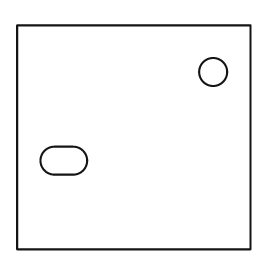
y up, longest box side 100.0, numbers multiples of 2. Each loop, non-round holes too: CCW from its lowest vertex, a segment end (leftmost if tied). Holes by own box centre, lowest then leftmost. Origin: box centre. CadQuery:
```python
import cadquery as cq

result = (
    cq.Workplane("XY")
    .moveTo(-50.0, -48.0)
    .lineTo(50.0, -48.0)
    .lineTo(50.0, 48.0)
    .lineTo(-50.0, 48.0)
    .close()
    .moveTo(-34.0, -16.0)
    .lineTo(-26.0, -16.0)
    .threePointArc((-20.0, -10.0), (-26.0, -4.0))
    .lineTo(-34.0, -4.0)
    .threePointArc((-40.0, -10.0), (-34.0, -16.0))
    .close()
    .moveTo(34.0, 28.0)
    .circle(6.0)
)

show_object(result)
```